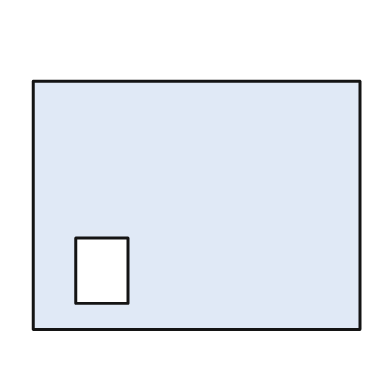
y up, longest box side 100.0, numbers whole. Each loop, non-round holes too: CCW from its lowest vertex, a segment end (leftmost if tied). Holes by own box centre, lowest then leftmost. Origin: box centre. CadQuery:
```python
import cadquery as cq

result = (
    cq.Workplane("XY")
    .moveTo(-50.0, -38.0)
    .lineTo(50.0, -38.0)
    .lineTo(50.0, 38.0)
    .lineTo(-50.0, 38.0)
    .close()
    .moveTo(-37.0, -30.0)
    .lineTo(-21.0, -30.0)
    .lineTo(-21.0, -10.0)
    .lineTo(-37.0, -10.0)
    .close()
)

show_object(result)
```